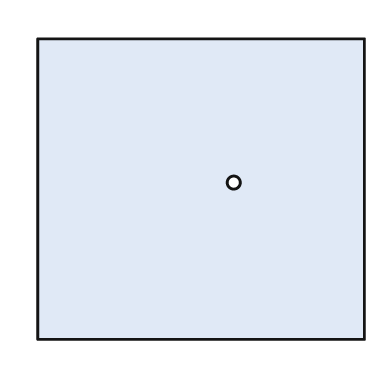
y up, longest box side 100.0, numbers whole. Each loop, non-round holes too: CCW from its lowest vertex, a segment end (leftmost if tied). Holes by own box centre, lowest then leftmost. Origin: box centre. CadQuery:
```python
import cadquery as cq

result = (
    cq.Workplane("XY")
    .moveTo(-50.0, -46.0)
    .lineTo(50.0, -46.0)
    .lineTo(50.0, 46.0)
    .lineTo(-50.0, 46.0)
    .close()
    .moveTo(10.0, 2.0)
    .circle(2.0)
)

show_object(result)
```